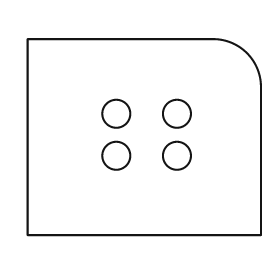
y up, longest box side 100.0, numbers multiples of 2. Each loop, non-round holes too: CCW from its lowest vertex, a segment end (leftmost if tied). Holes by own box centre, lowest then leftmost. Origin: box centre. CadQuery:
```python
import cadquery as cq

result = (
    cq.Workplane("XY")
    .moveTo(-50.0, -42.0)
    .lineTo(50.0, -42.0)
    .lineTo(50.0, 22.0)
    .threePointArc((44.0, 36.0), (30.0, 42.0))
    .lineTo(-50.0, 42.0)
    .close()
    .moveTo(-12.0, -8.0)
    .circle(6.0)
    .moveTo(14.0, -8.0)
    .circle(6.0)
    .moveTo(-12.0, 10.0)
    .circle(6.0)
    .moveTo(14.0, 10.0)
    .circle(6.0)
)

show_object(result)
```